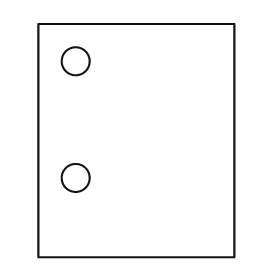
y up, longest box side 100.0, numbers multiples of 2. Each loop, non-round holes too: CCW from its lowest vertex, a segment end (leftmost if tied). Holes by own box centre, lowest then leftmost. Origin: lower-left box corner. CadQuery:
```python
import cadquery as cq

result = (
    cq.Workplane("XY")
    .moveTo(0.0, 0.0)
    .lineTo(84.0, 0.0)
    .lineTo(84.0, 100.0)
    .lineTo(0.0, 100.0)
    .close()
    .moveTo(16.0, 34.0)
    .circle(6.0)
    .moveTo(16.0, 84.0)
    .circle(6.0)
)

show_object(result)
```